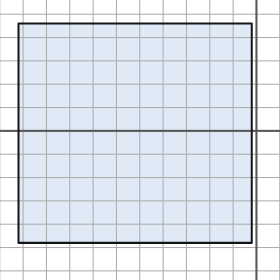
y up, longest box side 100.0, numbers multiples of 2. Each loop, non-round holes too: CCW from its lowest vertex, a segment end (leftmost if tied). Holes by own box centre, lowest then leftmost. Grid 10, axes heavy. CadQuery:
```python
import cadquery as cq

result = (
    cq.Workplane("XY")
    .moveTo(-102.0, -48.0)
    .lineTo(-2.0, -48.0)
    .lineTo(-2.0, 46.0)
    .lineTo(-102.0, 46.0)
    .close()
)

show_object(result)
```